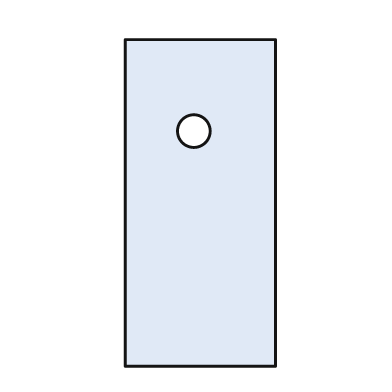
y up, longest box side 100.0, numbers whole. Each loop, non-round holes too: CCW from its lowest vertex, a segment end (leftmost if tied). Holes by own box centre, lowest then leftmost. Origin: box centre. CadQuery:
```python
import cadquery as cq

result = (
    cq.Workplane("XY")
    .moveTo(-23.0, -50.0)
    .lineTo(23.0, -50.0)
    .lineTo(23.0, 50.0)
    .lineTo(-23.0, 50.0)
    .close()
    .moveTo(-2.0, 22.0)
    .circle(5.0)
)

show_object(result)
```